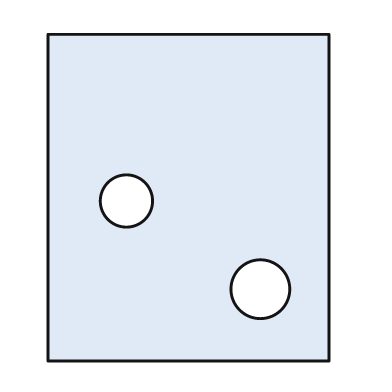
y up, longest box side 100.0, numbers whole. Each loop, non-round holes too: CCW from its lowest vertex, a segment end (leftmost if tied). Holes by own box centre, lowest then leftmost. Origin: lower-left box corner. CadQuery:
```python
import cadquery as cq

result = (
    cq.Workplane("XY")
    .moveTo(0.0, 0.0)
    .lineTo(86.0, 0.0)
    .lineTo(86.0, 100.0)
    .lineTo(0.0, 100.0)
    .close()
    .moveTo(65.0, 22.0)
    .circle(9.0)
    .moveTo(24.0, 49.0)
    .circle(8.0)
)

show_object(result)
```